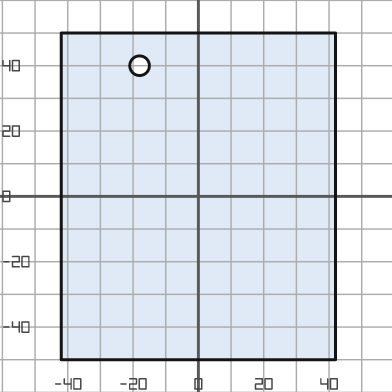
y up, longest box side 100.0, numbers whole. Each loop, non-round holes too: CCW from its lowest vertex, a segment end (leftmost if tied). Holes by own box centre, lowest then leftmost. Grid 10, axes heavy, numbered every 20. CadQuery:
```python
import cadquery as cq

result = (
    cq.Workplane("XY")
    .moveTo(-42.0, -50.0)
    .lineTo(42.0, -50.0)
    .lineTo(42.0, 50.0)
    .lineTo(-42.0, 50.0)
    .close()
    .moveTo(-18.0, 40.0)
    .circle(3.0)
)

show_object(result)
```